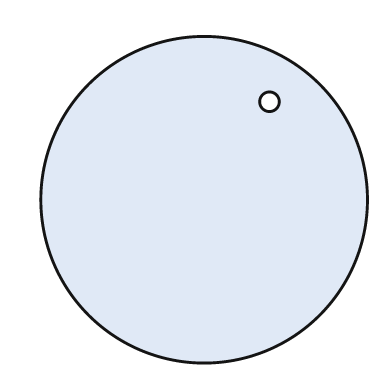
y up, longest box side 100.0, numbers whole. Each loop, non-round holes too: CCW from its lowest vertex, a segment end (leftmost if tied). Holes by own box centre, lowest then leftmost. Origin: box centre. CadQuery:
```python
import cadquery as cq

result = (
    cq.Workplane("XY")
    .moveTo(0.0, 0.0)
    .circle(50.0)
    .moveTo(20.0, 30.0)
    .circle(3.0)
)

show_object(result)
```